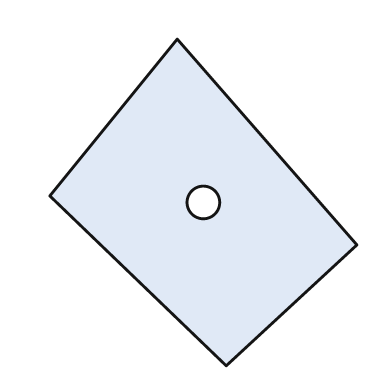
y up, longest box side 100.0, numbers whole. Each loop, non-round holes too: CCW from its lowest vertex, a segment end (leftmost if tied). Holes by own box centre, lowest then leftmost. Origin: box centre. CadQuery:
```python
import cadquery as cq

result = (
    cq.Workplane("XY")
    .moveTo(7.0, -50.0)
    .lineTo(47.0, -13.0)
    .lineTo(-8.0, 50.0)
    .lineTo(-47.0, 2.0)
    .close()
    .moveTo(0.0, 0.0)
    .circle(5.0)
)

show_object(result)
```